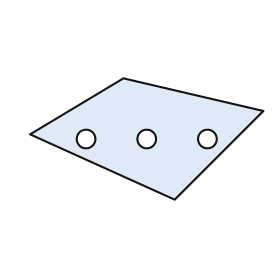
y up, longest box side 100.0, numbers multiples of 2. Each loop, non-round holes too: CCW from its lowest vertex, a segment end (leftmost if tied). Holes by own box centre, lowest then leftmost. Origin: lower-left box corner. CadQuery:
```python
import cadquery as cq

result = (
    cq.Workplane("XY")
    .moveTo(62.0, 0.0)
    .lineTo(100.0, 38.0)
    .lineTo(40.0, 52.0)
    .lineTo(0.0, 28.0)
    .close()
    .moveTo(24.0, 26.0)
    .circle(4.0)
    .moveTo(50.0, 26.0)
    .circle(4.0)
    .moveTo(76.0, 26.0)
    .circle(4.0)
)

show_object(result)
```